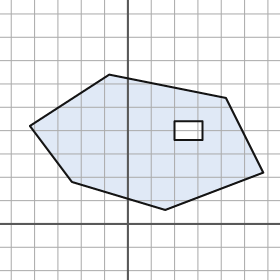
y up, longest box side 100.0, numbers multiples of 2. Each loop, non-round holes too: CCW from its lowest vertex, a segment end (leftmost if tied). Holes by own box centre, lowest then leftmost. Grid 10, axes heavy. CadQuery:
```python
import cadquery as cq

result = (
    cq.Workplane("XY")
    .moveTo(16.0, 6.0)
    .lineTo(58.0, 22.0)
    .lineTo(42.0, 54.0)
    .lineTo(-8.0, 64.0)
    .lineTo(-42.0, 42.0)
    .lineTo(-24.0, 18.0)
    .close()
    .moveTo(20.0, 36.0)
    .lineTo(32.0, 36.0)
    .lineTo(32.0, 44.0)
    .lineTo(20.0, 44.0)
    .close()
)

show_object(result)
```